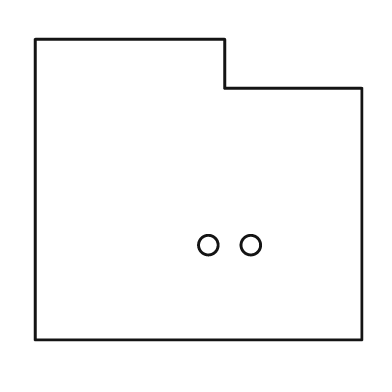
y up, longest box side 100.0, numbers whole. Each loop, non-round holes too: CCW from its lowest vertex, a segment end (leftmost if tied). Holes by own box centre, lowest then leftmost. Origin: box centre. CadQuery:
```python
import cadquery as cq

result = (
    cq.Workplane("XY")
    .moveTo(-50.0, -46.0)
    .lineTo(50.0, -46.0)
    .lineTo(50.0, 31.0)
    .lineTo(8.0, 31.0)
    .lineTo(8.0, 46.0)
    .lineTo(-50.0, 46.0)
    .close()
    .moveTo(3.0, -17.0)
    .circle(3.0)
    .moveTo(16.0, -17.0)
    .circle(3.0)
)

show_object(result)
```